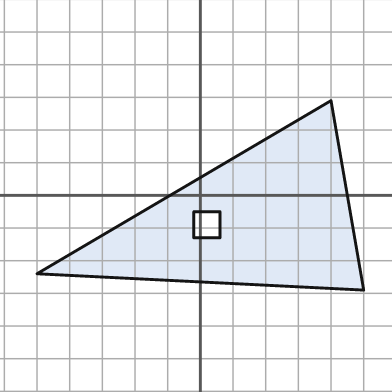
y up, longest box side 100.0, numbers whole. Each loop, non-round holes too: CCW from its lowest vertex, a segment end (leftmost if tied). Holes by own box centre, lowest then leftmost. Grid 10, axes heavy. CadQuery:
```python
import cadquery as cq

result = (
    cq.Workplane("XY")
    .moveTo(50.0, -29.0)
    .lineTo(40.0, 29.0)
    .lineTo(-50.0, -24.0)
    .close()
    .moveTo(-2.0, -13.0)
    .lineTo(6.0, -13.0)
    .lineTo(6.0, -5.0)
    .lineTo(-2.0, -5.0)
    .close()
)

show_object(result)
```